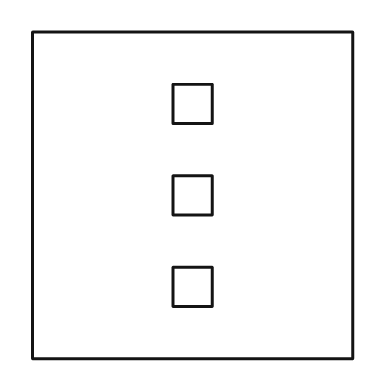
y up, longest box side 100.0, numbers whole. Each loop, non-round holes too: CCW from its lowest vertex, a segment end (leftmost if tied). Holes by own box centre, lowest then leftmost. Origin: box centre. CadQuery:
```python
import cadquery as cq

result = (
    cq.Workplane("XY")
    .moveTo(-49.0, -50.0)
    .lineTo(49.0, -50.0)
    .lineTo(49.0, 50.0)
    .lineTo(-49.0, 50.0)
    .close()
    .moveTo(-6.0, -34.0)
    .lineTo(6.0, -34.0)
    .lineTo(6.0, -22.0)
    .lineTo(-6.0, -22.0)
    .close()
    .moveTo(-6.0, -6.0)
    .lineTo(6.0, -6.0)
    .lineTo(6.0, 6.0)
    .lineTo(-6.0, 6.0)
    .close()
    .moveTo(-6.0, 22.0)
    .lineTo(6.0, 22.0)
    .lineTo(6.0, 34.0)
    .lineTo(-6.0, 34.0)
    .close()
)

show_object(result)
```